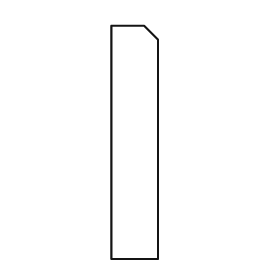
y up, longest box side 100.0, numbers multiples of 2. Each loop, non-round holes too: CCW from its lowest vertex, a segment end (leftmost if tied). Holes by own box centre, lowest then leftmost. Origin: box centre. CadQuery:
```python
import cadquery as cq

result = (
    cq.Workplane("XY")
    .moveTo(-10.0, -50.0)
    .lineTo(10.0, -50.0)
    .lineTo(10.0, 44.0)
    .lineTo(4.0, 50.0)
    .lineTo(-10.0, 50.0)
    .close()
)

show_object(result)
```